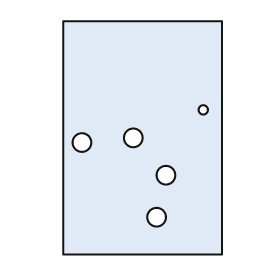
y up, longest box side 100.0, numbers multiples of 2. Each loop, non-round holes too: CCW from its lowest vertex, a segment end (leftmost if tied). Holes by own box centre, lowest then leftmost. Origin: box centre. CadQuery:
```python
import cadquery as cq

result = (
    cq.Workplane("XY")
    .moveTo(-34.0, -50.0)
    .lineTo(34.0, -50.0)
    .lineTo(34.0, 50.0)
    .lineTo(-34.0, 50.0)
    .close()
    .moveTo(6.0, -34.0)
    .circle(4.0)
    .moveTo(10.0, -16.0)
    .circle(4.0)
    .moveTo(-26.0, -2.0)
    .circle(4.0)
    .moveTo(-4.0, 0.0)
    .circle(4.0)
    .moveTo(26.0, 12.0)
    .circle(2.0)
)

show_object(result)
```